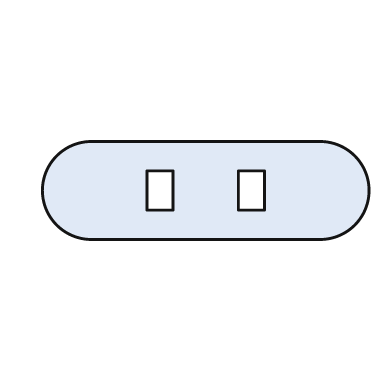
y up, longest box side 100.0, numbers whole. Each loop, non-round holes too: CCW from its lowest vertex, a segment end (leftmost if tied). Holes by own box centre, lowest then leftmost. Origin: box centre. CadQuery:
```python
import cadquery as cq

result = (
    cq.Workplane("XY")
    .moveTo(-35.0, -15.0)
    .lineTo(35.0, -15.0)
    .threePointArc((50.0, 0.0), (35.0, 15.0))
    .lineTo(-35.0, 15.0)
    .threePointArc((-50.0, 0.0), (-35.0, -15.0))
    .close()
    .moveTo(-18.0, -6.0)
    .lineTo(-10.0, -6.0)
    .lineTo(-10.0, 6.0)
    .lineTo(-18.0, 6.0)
    .close()
    .moveTo(10.0, -6.0)
    .lineTo(18.0, -6.0)
    .lineTo(18.0, 6.0)
    .lineTo(10.0, 6.0)
    .close()
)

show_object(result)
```